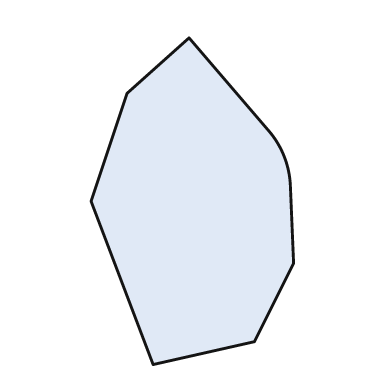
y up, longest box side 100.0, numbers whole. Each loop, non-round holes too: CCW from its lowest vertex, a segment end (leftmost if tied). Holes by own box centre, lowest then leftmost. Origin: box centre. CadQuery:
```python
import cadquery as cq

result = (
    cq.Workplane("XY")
    .moveTo(-12.0, -50.0)
    .lineTo(19.0, -43.0)
    .lineTo(31.0, -19.0)
    .lineTo(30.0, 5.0)
    .threePointArc((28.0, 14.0), (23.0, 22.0))
    .lineTo(-1.0, 50.0)
    .lineTo(-20.0, 33.0)
    .lineTo(-31.0, 0.0)
    .close()
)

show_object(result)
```